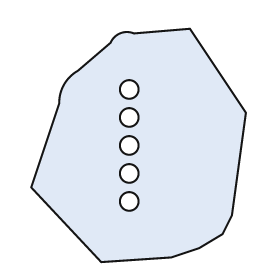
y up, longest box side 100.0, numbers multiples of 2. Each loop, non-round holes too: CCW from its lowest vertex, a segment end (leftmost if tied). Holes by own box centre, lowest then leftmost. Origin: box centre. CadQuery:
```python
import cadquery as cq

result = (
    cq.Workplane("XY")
    .moveTo(-16.0, -50.0)
    .lineTo(14.0, -48.0)
    .lineTo(26.0, -44.0)
    .lineTo(36.0, -38.0)
    .lineTo(40.0, -30.0)
    .lineTo(46.0, 14.0)
    .lineTo(22.0, 50.0)
    .lineTo(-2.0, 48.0)
    .threePointArc((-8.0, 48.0), (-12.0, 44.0))
    .lineTo(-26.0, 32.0)
    .threePointArc((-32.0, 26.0), (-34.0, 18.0))
    .lineTo(-46.0, -18.0)
    .close()
    .moveTo(-4.0, -24.0)
    .circle(4.0)
    .moveTo(-4.0, -12.0)
    .circle(4.0)
    .moveTo(-4.0, 0.0)
    .circle(4.0)
    .moveTo(-4.0, 12.0)
    .circle(4.0)
    .moveTo(-4.0, 24.0)
    .circle(4.0)
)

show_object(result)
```